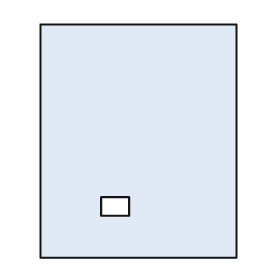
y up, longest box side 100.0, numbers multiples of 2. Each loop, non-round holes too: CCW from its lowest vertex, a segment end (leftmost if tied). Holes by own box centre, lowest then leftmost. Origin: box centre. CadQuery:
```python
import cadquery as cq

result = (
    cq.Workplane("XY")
    .moveTo(-42.0, -50.0)
    .lineTo(42.0, -50.0)
    .lineTo(42.0, 50.0)
    .lineTo(-42.0, 50.0)
    .close()
    .moveTo(-16.0, -32.0)
    .lineTo(-4.0, -32.0)
    .lineTo(-4.0, -24.0)
    .lineTo(-16.0, -24.0)
    .close()
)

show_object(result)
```